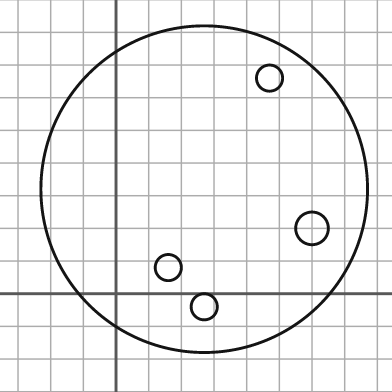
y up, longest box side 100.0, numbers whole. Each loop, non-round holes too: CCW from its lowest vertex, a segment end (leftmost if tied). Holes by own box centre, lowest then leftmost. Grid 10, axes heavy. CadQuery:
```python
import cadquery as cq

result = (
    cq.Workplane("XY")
    .moveTo(27.0, 32.0)
    .circle(50.0)
    .moveTo(27.0, -4.0)
    .circle(4.0)
    .moveTo(16.0, 8.0)
    .circle(4.0)
    .moveTo(60.0, 20.0)
    .circle(5.0)
    .moveTo(47.0, 66.0)
    .circle(4.0)
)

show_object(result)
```